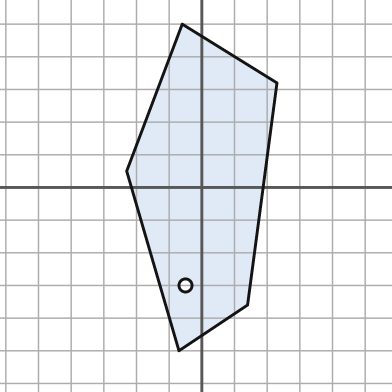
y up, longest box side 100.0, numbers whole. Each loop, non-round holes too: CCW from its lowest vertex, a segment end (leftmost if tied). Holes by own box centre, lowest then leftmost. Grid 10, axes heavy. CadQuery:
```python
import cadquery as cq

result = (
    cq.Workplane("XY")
    .moveTo(-7.0, -50.0)
    .lineTo(14.0, -36.0)
    .lineTo(23.0, 32.0)
    .lineTo(-6.0, 50.0)
    .lineTo(-23.0, 5.0)
    .close()
    .moveTo(-5.0, -30.0)
    .circle(2.0)
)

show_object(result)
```